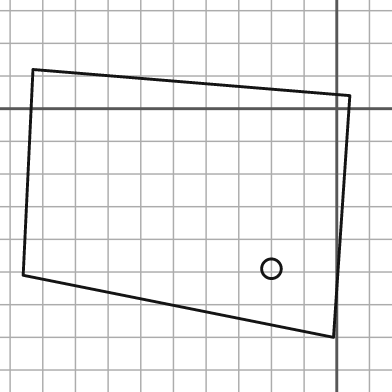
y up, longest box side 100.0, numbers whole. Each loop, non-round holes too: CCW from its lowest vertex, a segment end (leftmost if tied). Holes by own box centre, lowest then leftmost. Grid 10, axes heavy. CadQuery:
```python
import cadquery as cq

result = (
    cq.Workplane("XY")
    .moveTo(-1.0, -70.0)
    .lineTo(4.0, 4.0)
    .lineTo(-93.0, 12.0)
    .lineTo(-96.0, -51.0)
    .close()
    .moveTo(-20.0, -49.0)
    .circle(3.0)
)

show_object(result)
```